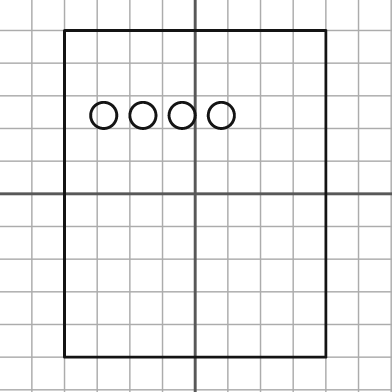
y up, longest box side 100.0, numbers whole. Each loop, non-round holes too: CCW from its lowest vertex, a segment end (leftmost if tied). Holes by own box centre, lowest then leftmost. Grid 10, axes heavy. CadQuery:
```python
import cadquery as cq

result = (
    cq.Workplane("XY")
    .moveTo(-40.0, -50.0)
    .lineTo(40.0, -50.0)
    .lineTo(40.0, 50.0)
    .lineTo(-40.0, 50.0)
    .close()
    .moveTo(-28.0, 24.0)
    .circle(4.0)
    .moveTo(-16.0, 24.0)
    .circle(4.0)
    .moveTo(-4.0, 24.0)
    .circle(4.0)
    .moveTo(8.0, 24.0)
    .circle(4.0)
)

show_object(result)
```